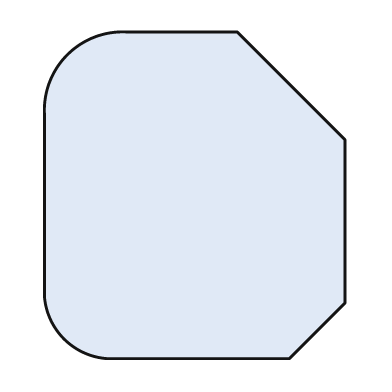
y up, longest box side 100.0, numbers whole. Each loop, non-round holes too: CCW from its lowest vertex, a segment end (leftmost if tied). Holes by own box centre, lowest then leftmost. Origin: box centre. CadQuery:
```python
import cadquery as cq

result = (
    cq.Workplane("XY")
    .moveTo(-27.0, -50.0)
    .lineTo(29.0, -50.0)
    .lineTo(46.0, -33.0)
    .lineTo(46.0, 17.0)
    .lineTo(13.0, 50.0)
    .lineTo(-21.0, 50.0)
    .threePointArc((-39.0, 43.0), (-46.0, 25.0))
    .lineTo(-46.0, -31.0)
    .threePointArc((-40.0, -44.0), (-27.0, -50.0))
    .close()
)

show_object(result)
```